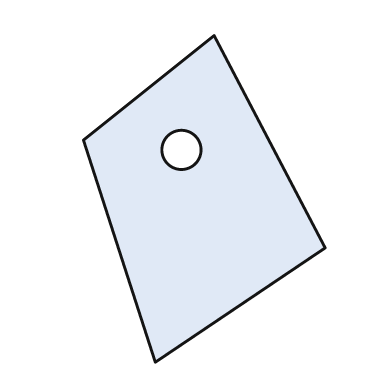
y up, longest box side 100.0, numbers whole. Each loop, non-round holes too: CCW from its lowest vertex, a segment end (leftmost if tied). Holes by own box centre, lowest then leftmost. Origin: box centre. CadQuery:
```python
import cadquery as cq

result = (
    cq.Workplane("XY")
    .moveTo(-15.0, -50.0)
    .lineTo(37.0, -15.0)
    .lineTo(3.0, 50.0)
    .lineTo(-37.0, 18.0)
    .close()
    .moveTo(-7.0, 15.0)
    .circle(6.0)
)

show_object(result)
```